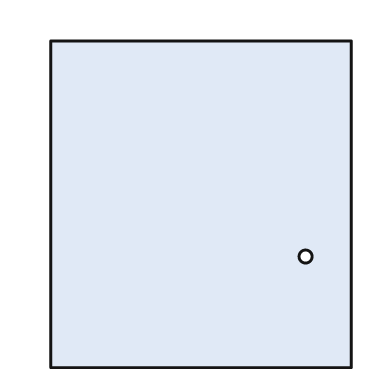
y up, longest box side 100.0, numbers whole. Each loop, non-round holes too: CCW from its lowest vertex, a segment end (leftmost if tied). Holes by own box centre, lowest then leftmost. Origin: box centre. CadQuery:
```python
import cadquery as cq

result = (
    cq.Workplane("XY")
    .moveTo(-46.0, -50.0)
    .lineTo(46.0, -50.0)
    .lineTo(46.0, 50.0)
    .lineTo(-46.0, 50.0)
    .close()
    .moveTo(32.0, -16.0)
    .circle(2.0)
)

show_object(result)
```